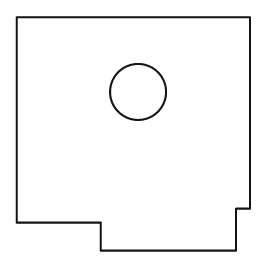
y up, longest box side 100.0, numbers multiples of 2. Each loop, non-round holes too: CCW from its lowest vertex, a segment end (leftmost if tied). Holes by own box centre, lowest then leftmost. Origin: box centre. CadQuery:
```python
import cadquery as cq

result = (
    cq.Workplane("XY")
    .moveTo(-14.0, -50.0)
    .lineTo(44.0, -50.0)
    .lineTo(44.0, -32.0)
    .lineTo(50.0, -32.0)
    .lineTo(50.0, 50.0)
    .lineTo(-50.0, 50.0)
    .lineTo(-50.0, -38.0)
    .lineTo(-14.0, -38.0)
    .close()
    .moveTo(2.0, 18.0)
    .circle(12.0)
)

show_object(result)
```